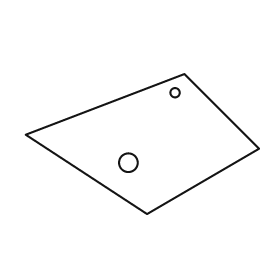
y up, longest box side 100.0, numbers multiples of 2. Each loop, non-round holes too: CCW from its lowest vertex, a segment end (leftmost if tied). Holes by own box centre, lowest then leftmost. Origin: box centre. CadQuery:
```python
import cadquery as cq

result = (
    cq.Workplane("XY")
    .moveTo(2.0, -30.0)
    .lineTo(50.0, -2.0)
    .lineTo(18.0, 30.0)
    .lineTo(-50.0, 4.0)
    .close()
    .moveTo(-6.0, -8.0)
    .circle(4.0)
    .moveTo(14.0, 22.0)
    .circle(2.0)
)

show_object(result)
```